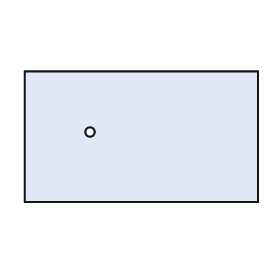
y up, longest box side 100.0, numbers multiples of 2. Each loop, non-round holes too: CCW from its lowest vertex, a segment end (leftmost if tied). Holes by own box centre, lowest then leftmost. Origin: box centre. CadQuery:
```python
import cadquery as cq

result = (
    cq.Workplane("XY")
    .moveTo(-50.0, -28.0)
    .lineTo(50.0, -28.0)
    .lineTo(50.0, 28.0)
    .lineTo(-50.0, 28.0)
    .close()
    .moveTo(-22.0, 2.0)
    .circle(2.0)
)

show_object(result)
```